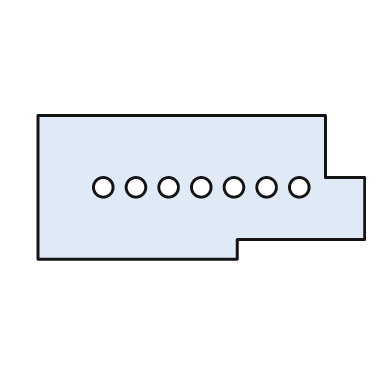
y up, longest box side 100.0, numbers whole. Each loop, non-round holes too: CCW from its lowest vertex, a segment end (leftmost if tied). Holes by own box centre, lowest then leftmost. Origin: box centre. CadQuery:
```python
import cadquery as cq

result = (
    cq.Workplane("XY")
    .moveTo(-50.0, -22.0)
    .lineTo(11.0, -22.0)
    .lineTo(11.0, -16.0)
    .lineTo(50.0, -16.0)
    .lineTo(50.0, 3.0)
    .lineTo(38.0, 3.0)
    .lineTo(38.0, 22.0)
    .lineTo(-50.0, 22.0)
    .close()
    .moveTo(-30.0, 0.0)
    .circle(3.0)
    .moveTo(-20.0, 0.0)
    .circle(3.0)
    .moveTo(-10.0, 0.0)
    .circle(3.0)
    .moveTo(0.0, 0.0)
    .circle(3.0)
    .moveTo(10.0, 0.0)
    .circle(3.0)
    .moveTo(20.0, 0.0)
    .circle(3.0)
    .moveTo(30.0, 0.0)
    .circle(3.0)
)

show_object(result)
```